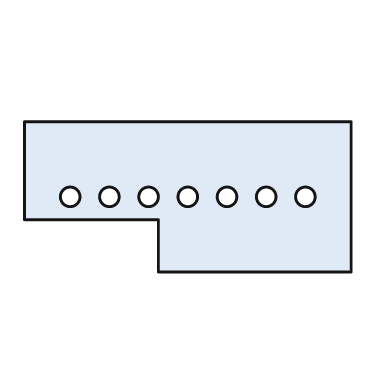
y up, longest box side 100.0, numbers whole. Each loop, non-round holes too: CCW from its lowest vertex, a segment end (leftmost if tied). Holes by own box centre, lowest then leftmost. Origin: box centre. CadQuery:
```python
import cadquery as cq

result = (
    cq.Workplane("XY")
    .moveTo(-9.0, -23.0)
    .lineTo(50.0, -23.0)
    .lineTo(50.0, 23.0)
    .lineTo(-50.0, 23.0)
    .lineTo(-50.0, -7.0)
    .lineTo(-9.0, -7.0)
    .close()
    .moveTo(-36.0, 0.0)
    .circle(3.0)
    .moveTo(-24.0, 0.0)
    .circle(3.0)
    .moveTo(-12.0, 0.0)
    .circle(3.0)
    .moveTo(0.0, 0.0)
    .circle(3.0)
    .moveTo(12.0, 0.0)
    .circle(3.0)
    .moveTo(24.0, 0.0)
    .circle(3.0)
    .moveTo(36.0, 0.0)
    .circle(3.0)
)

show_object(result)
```